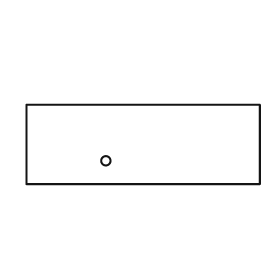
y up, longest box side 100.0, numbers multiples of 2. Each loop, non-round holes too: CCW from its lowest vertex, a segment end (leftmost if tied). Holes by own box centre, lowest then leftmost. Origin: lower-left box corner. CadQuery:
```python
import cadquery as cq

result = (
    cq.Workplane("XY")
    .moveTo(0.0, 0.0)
    .lineTo(100.0, 0.0)
    .lineTo(100.0, 34.0)
    .lineTo(0.0, 34.0)
    .close()
    .moveTo(34.0, 10.0)
    .circle(2.0)
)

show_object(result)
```